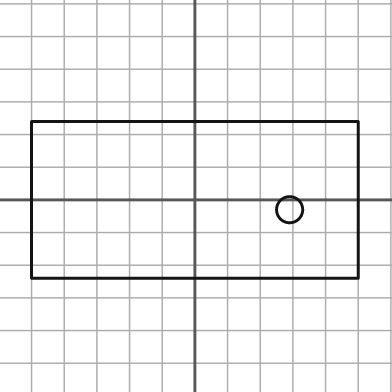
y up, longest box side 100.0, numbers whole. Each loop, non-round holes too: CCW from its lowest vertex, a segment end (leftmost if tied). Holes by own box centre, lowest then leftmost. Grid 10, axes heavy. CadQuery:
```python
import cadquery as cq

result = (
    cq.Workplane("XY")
    .moveTo(-50.0, -24.0)
    .lineTo(50.0, -24.0)
    .lineTo(50.0, 24.0)
    .lineTo(-50.0, 24.0)
    .close()
    .moveTo(29.0, -3.0)
    .circle(4.0)
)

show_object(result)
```